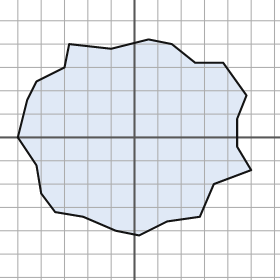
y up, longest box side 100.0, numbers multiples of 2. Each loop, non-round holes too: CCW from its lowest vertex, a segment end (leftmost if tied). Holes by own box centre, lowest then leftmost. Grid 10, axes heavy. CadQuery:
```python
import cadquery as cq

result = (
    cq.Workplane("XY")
    .moveTo(2.0, -42.0)
    .lineTo(14.0, -36.0)
    .lineTo(28.0, -34.0)
    .lineTo(34.0, -20.0)
    .lineTo(50.0, -14.0)
    .lineTo(44.0, -4.0)
    .lineTo(44.0, 8.0)
    .lineTo(48.0, 18.0)
    .lineTo(38.0, 32.0)
    .lineTo(26.0, 32.0)
    .lineTo(16.0, 40.0)
    .lineTo(6.0, 42.0)
    .lineTo(-10.0, 38.0)
    .lineTo(-28.0, 40.0)
    .lineTo(-30.0, 30.0)
    .lineTo(-42.0, 24.0)
    .lineTo(-46.0, 16.0)
    .lineTo(-50.0, 0.0)
    .lineTo(-42.0, -12.0)
    .lineTo(-40.0, -24.0)
    .lineTo(-34.0, -32.0)
    .lineTo(-22.0, -34.0)
    .lineTo(-8.0, -40.0)
    .close()
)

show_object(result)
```